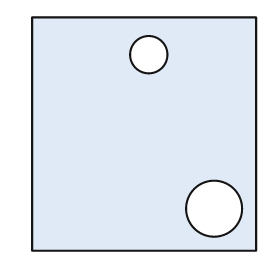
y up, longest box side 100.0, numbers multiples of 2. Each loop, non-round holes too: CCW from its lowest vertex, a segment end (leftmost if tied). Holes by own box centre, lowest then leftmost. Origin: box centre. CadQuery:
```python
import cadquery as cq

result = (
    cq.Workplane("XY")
    .moveTo(-48.0, -50.0)
    .lineTo(48.0, -50.0)
    .lineTo(48.0, 50.0)
    .lineTo(-48.0, 50.0)
    .close()
    .moveTo(30.0, -32.0)
    .circle(12.0)
    .moveTo(2.0, 34.0)
    .circle(8.0)
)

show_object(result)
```